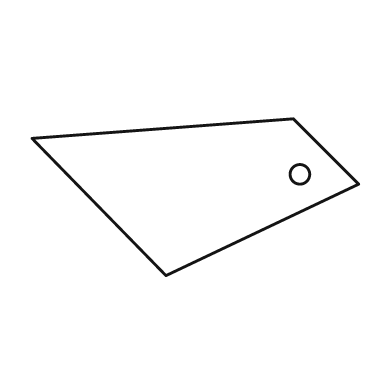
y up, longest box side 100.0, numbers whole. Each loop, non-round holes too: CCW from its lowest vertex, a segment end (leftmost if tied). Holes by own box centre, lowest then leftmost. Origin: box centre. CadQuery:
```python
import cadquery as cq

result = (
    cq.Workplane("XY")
    .moveTo(-9.0, -24.0)
    .lineTo(50.0, 4.0)
    .lineTo(30.0, 24.0)
    .lineTo(-50.0, 18.0)
    .close()
    .moveTo(32.0, 7.0)
    .circle(3.0)
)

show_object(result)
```